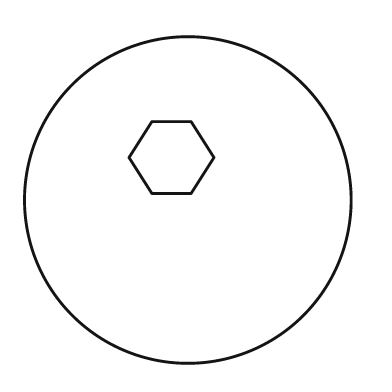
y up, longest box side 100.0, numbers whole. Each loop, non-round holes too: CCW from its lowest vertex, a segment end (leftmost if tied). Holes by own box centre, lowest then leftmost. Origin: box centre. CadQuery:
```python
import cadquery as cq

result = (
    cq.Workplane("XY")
    .moveTo(0.0, 0.0)
    .circle(50.0)
    .moveTo(-11.0, 2.0)
    .lineTo(1.0, 2.0)
    .lineTo(8.0, 13.0)
    .lineTo(1.0, 24.0)
    .lineTo(-11.0, 24.0)
    .lineTo(-18.0, 13.0)
    .close()
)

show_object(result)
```